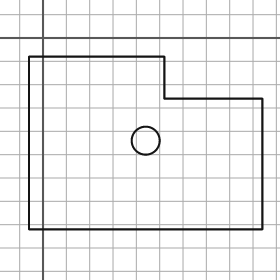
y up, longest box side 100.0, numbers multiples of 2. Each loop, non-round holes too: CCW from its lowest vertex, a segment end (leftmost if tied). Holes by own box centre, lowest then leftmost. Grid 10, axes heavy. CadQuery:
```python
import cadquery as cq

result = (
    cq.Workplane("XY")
    .moveTo(-6.0, -82.0)
    .lineTo(94.0, -82.0)
    .lineTo(94.0, -26.0)
    .lineTo(52.0, -26.0)
    .lineTo(52.0, -8.0)
    .lineTo(-6.0, -8.0)
    .close()
    .moveTo(44.0, -44.0)
    .circle(6.0)
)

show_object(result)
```